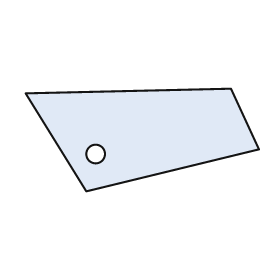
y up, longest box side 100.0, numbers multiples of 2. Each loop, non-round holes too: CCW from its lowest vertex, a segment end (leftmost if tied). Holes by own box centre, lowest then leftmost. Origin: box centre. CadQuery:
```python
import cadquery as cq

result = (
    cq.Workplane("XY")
    .moveTo(-24.0, -22.0)
    .lineTo(50.0, -4.0)
    .lineTo(38.0, 22.0)
    .lineTo(-50.0, 20.0)
    .close()
    .moveTo(-20.0, -6.0)
    .circle(4.0)
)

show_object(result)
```